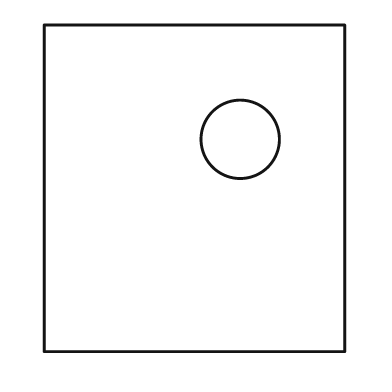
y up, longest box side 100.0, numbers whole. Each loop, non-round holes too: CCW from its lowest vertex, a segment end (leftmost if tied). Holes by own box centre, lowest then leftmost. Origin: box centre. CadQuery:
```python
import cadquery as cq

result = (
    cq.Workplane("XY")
    .moveTo(-46.0, -50.0)
    .lineTo(46.0, -50.0)
    .lineTo(46.0, 50.0)
    .lineTo(-46.0, 50.0)
    .close()
    .moveTo(14.0, 15.0)
    .circle(12.0)
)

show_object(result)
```